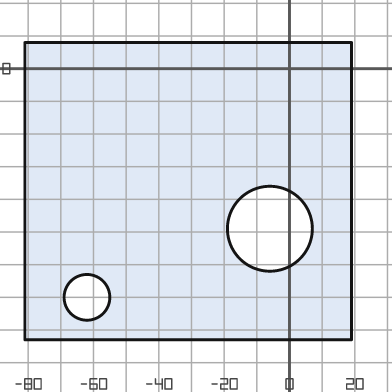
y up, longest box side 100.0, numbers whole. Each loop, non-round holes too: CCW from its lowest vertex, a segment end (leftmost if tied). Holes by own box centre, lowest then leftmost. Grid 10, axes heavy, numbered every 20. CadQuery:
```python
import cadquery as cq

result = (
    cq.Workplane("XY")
    .moveTo(-81.0, -83.0)
    .lineTo(19.0, -83.0)
    .lineTo(19.0, 8.0)
    .lineTo(-81.0, 8.0)
    .close()
    .moveTo(-62.0, -70.0)
    .circle(7.0)
    .moveTo(-6.0, -49.0)
    .circle(13.0)
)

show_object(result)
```